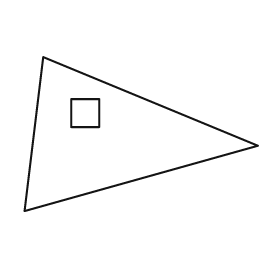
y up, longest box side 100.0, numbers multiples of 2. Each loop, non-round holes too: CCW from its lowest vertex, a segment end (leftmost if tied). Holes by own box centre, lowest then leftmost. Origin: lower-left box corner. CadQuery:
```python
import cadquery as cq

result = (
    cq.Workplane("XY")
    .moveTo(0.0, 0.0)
    .lineTo(100.0, 28.0)
    .lineTo(8.0, 66.0)
    .close()
    .moveTo(20.0, 36.0)
    .lineTo(32.0, 36.0)
    .lineTo(32.0, 48.0)
    .lineTo(20.0, 48.0)
    .close()
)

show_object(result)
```